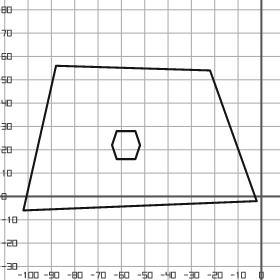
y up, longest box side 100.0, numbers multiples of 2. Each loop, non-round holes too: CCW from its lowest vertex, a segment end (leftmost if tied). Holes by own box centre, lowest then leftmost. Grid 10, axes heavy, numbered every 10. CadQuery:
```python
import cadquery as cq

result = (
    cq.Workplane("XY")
    .moveTo(-102.0, -6.0)
    .lineTo(-2.0, -2.0)
    .lineTo(-22.0, 54.0)
    .lineTo(-88.0, 56.0)
    .close()
    .moveTo(-62.0, 16.0)
    .lineTo(-54.0, 16.0)
    .lineTo(-52.0, 22.0)
    .lineTo(-54.0, 28.0)
    .lineTo(-62.0, 28.0)
    .lineTo(-64.0, 22.0)
    .close()
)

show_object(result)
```